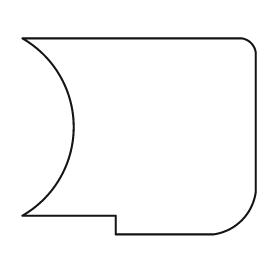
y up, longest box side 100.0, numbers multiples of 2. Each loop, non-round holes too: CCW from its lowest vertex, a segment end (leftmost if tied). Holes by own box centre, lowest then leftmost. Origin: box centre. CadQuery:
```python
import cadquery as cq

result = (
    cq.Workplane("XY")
    .moveTo(-10.0, -42.0)
    .lineTo(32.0, -42.0)
    .threePointArc((44.0, -36.0), (50.0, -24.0))
    .lineTo(50.0, 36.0)
    .threePointArc((48.0, 40.0), (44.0, 42.0))
    .lineTo(-50.0, 42.0)
    .threePointArc((-28.0, 4.0), (-50.0, -34.0))
    .lineTo(-10.0, -34.0)
    .close()
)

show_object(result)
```